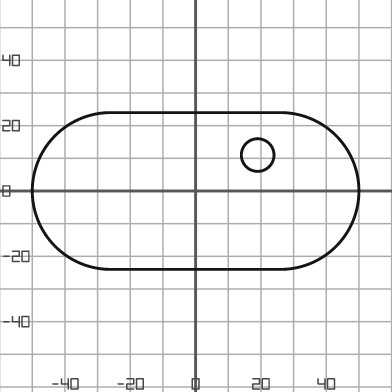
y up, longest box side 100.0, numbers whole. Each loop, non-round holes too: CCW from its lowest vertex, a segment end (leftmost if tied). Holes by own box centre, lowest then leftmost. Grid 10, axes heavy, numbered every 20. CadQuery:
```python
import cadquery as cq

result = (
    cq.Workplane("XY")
    .moveTo(-26.0, -24.0)
    .lineTo(26.0, -24.0)
    .threePointArc((50.0, 0.0), (26.0, 24.0))
    .lineTo(-26.0, 24.0)
    .threePointArc((-50.0, 0.0), (-26.0, -24.0))
    .close()
    .moveTo(19.0, 11.0)
    .circle(5.0)
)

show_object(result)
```